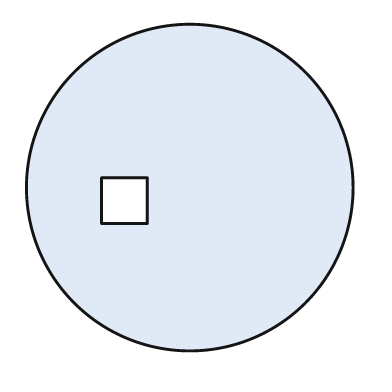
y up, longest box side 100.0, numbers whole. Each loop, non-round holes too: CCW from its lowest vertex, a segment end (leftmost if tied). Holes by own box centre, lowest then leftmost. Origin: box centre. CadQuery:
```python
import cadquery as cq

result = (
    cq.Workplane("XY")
    .moveTo(0.0, 0.0)
    .circle(50.0)
    .moveTo(-27.0, -11.0)
    .lineTo(-13.0, -11.0)
    .lineTo(-13.0, 3.0)
    .lineTo(-27.0, 3.0)
    .close()
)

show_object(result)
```